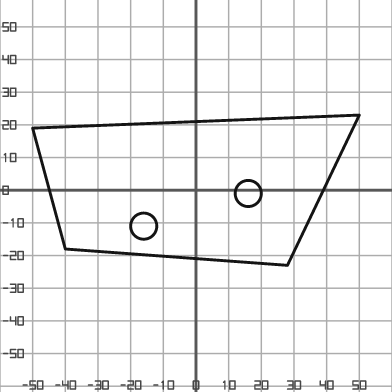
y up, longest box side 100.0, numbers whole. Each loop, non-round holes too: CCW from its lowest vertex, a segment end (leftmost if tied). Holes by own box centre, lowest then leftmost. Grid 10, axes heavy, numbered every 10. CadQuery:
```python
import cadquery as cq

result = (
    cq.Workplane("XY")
    .moveTo(28.0, -23.0)
    .lineTo(50.0, 23.0)
    .lineTo(-50.0, 19.0)
    .lineTo(-40.0, -18.0)
    .close()
    .moveTo(-16.0, -11.0)
    .circle(4.0)
    .moveTo(16.0, -1.0)
    .circle(4.0)
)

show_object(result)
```